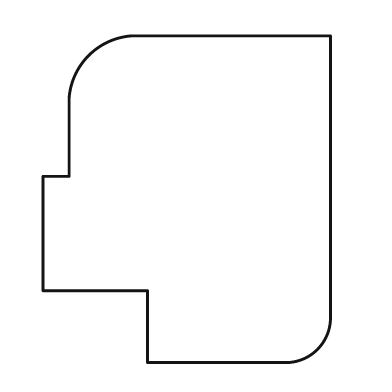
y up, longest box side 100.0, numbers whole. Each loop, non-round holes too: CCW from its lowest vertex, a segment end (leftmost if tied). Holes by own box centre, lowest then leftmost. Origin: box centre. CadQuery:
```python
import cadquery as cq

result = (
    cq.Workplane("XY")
    .moveTo(-12.0, -50.0)
    .lineTo(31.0, -50.0)
    .threePointArc((40.0, -46.0), (44.0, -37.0))
    .lineTo(44.0, 50.0)
    .lineTo(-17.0, 50.0)
    .threePointArc((-30.0, 44.0), (-36.0, 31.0))
    .lineTo(-36.0, 7.0)
    .lineTo(-44.0, 7.0)
    .lineTo(-44.0, -28.0)
    .lineTo(-12.0, -28.0)
    .close()
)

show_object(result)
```